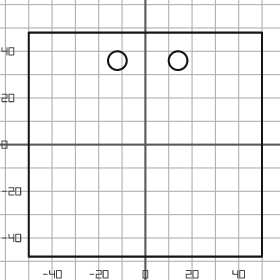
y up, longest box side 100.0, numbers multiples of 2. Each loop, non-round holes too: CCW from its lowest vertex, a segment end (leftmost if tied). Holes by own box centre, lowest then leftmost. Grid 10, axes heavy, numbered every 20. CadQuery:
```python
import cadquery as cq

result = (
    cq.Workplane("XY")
    .moveTo(-50.0, -48.0)
    .lineTo(50.0, -48.0)
    .lineTo(50.0, 48.0)
    .lineTo(-50.0, 48.0)
    .close()
    .moveTo(-12.0, 36.0)
    .circle(4.0)
    .moveTo(14.0, 36.0)
    .circle(4.0)
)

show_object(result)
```